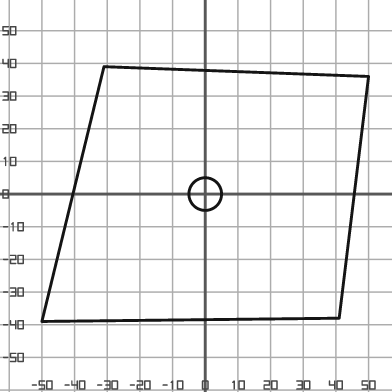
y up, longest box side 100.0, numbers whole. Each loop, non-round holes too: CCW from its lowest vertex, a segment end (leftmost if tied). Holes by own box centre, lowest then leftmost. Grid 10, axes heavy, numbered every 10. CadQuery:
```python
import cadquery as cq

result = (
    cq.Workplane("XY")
    .moveTo(-50.0, -39.0)
    .lineTo(41.0, -38.0)
    .lineTo(50.0, 36.0)
    .lineTo(-31.0, 39.0)
    .close()
    .moveTo(0.0, 0.0)
    .circle(5.0)
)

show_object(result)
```